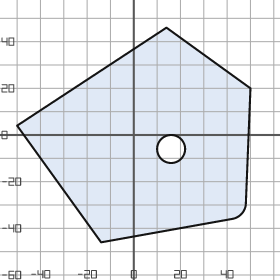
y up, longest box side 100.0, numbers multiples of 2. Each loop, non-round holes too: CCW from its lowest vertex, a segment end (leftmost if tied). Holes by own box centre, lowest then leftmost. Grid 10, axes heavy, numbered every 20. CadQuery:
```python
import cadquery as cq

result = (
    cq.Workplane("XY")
    .moveTo(-14.0, -46.0)
    .lineTo(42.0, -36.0)
    .threePointArc((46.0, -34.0), (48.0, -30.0))
    .lineTo(50.0, 20.0)
    .lineTo(14.0, 46.0)
    .lineTo(-50.0, 4.0)
    .close()
    .moveTo(16.0, -6.0)
    .circle(6.0)
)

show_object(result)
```